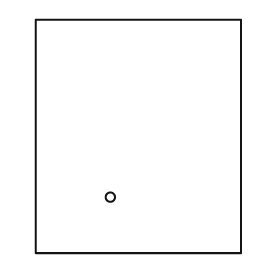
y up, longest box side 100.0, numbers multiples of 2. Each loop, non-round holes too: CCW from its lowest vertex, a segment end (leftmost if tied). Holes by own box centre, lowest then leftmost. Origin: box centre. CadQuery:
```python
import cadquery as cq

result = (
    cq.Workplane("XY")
    .moveTo(-44.0, -50.0)
    .lineTo(44.0, -50.0)
    .lineTo(44.0, 50.0)
    .lineTo(-44.0, 50.0)
    .close()
    .moveTo(-12.0, -26.0)
    .circle(2.0)
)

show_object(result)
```